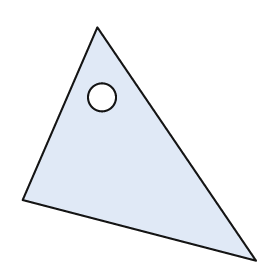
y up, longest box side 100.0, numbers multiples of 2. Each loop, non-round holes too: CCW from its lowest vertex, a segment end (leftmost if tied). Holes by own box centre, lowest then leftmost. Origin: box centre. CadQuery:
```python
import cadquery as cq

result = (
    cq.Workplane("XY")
    .moveTo(50.0, -50.0)
    .lineTo(-18.0, 50.0)
    .lineTo(-50.0, -24.0)
    .close()
    .moveTo(-16.0, 20.0)
    .circle(6.0)
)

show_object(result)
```